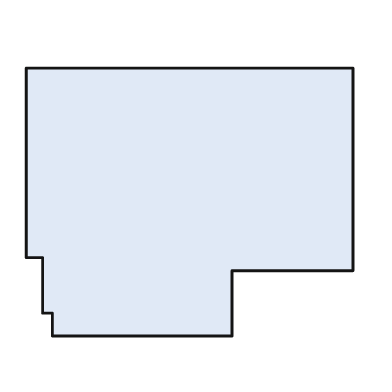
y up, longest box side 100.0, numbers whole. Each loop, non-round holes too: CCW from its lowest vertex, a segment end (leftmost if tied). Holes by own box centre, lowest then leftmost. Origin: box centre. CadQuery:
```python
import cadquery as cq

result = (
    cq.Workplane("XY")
    .moveTo(-42.0, -41.0)
    .lineTo(13.0, -41.0)
    .lineTo(13.0, -21.0)
    .lineTo(50.0, -21.0)
    .lineTo(50.0, 41.0)
    .lineTo(-50.0, 41.0)
    .lineTo(-50.0, -17.0)
    .lineTo(-45.0, -17.0)
    .lineTo(-45.0, -34.0)
    .lineTo(-42.0, -34.0)
    .close()
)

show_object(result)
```